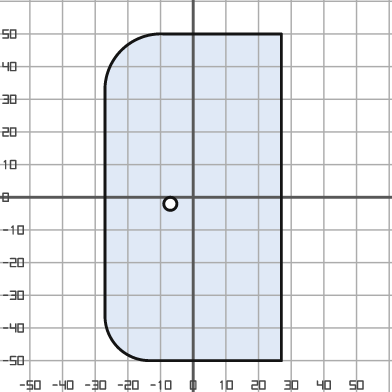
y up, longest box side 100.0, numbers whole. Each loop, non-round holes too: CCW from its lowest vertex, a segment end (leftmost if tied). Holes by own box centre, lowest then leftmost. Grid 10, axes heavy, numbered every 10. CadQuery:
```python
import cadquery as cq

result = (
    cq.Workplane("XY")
    .moveTo(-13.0, -50.0)
    .lineTo(27.0, -50.0)
    .lineTo(27.0, 50.0)
    .lineTo(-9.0, 50.0)
    .threePointArc((-22.0, 45.0), (-27.0, 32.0))
    .lineTo(-27.0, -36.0)
    .threePointArc((-23.0, -46.0), (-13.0, -50.0))
    .close()
    .moveTo(-7.0, -2.0)
    .circle(2.0)
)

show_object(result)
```